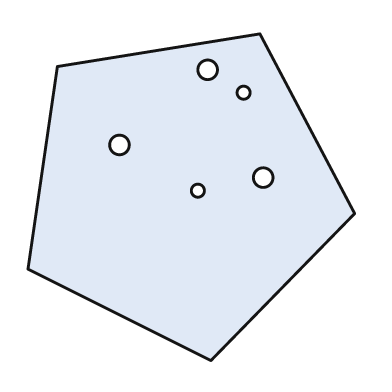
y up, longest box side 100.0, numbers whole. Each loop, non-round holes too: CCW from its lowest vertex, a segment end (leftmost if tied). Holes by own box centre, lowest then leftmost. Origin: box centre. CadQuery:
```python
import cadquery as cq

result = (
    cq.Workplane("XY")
    .moveTo(6.0, -50.0)
    .lineTo(50.0, -5.0)
    .lineTo(21.0, 50.0)
    .lineTo(-41.0, 40.0)
    .lineTo(-50.0, -22.0)
    .close()
    .moveTo(2.0, 2.0)
    .circle(2.0)
    .moveTo(22.0, 6.0)
    .circle(3.0)
    .moveTo(-22.0, 16.0)
    .circle(3.0)
    .moveTo(16.0, 32.0)
    .circle(2.0)
    .moveTo(5.0, 39.0)
    .circle(3.0)
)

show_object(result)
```